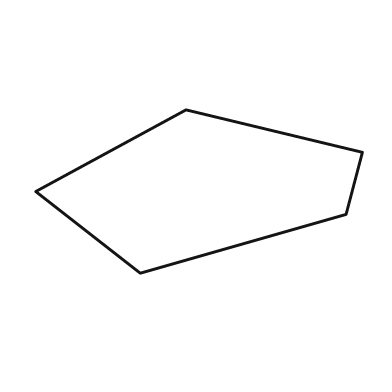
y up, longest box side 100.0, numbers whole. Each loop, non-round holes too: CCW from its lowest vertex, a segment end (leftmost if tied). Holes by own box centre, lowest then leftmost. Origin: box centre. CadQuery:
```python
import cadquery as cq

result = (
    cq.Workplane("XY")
    .moveTo(-18.0, -25.0)
    .lineTo(45.0, -7.0)
    .lineTo(50.0, 12.0)
    .lineTo(-4.0, 25.0)
    .lineTo(-50.0, 0.0)
    .close()
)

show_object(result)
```